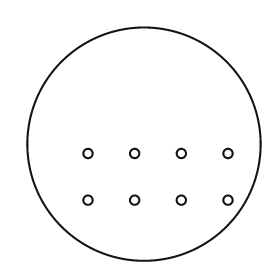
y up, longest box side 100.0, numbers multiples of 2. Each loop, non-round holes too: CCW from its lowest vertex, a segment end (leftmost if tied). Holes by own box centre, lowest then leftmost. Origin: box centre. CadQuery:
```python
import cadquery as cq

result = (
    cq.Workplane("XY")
    .moveTo(0.0, 0.0)
    .circle(50.0)
    .moveTo(-24.0, -24.0)
    .circle(2.0)
    .moveTo(-4.0, -24.0)
    .circle(2.0)
    .moveTo(16.0, -24.0)
    .circle(2.0)
    .moveTo(36.0, -24.0)
    .circle(2.0)
    .moveTo(-24.0, -4.0)
    .circle(2.0)
    .moveTo(-4.0, -4.0)
    .circle(2.0)
    .moveTo(16.0, -4.0)
    .circle(2.0)
    .moveTo(36.0, -4.0)
    .circle(2.0)
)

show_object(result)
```